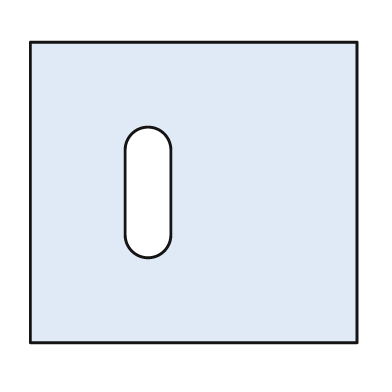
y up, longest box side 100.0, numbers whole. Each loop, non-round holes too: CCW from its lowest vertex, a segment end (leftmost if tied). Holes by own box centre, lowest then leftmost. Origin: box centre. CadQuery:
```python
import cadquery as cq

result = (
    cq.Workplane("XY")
    .moveTo(-50.0, -46.0)
    .lineTo(50.0, -46.0)
    .lineTo(50.0, 46.0)
    .lineTo(-50.0, 46.0)
    .close()
    .moveTo(-21.0, -13.0)
    .threePointArc((-14.0, -20.0), (-7.0, -13.0))
    .lineTo(-7.0, 13.0)
    .threePointArc((-14.0, 20.0), (-21.0, 13.0))
    .close()
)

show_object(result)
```